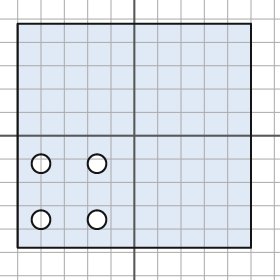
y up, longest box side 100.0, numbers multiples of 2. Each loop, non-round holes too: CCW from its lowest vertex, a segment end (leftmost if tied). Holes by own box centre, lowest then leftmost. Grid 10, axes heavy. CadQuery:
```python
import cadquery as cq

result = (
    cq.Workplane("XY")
    .moveTo(-50.0, -48.0)
    .lineTo(50.0, -48.0)
    .lineTo(50.0, 48.0)
    .lineTo(-50.0, 48.0)
    .close()
    .moveTo(-40.0, -36.0)
    .circle(4.0)
    .moveTo(-16.0, -36.0)
    .circle(4.0)
    .moveTo(-40.0, -12.0)
    .circle(4.0)
    .moveTo(-16.0, -12.0)
    .circle(4.0)
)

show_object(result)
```